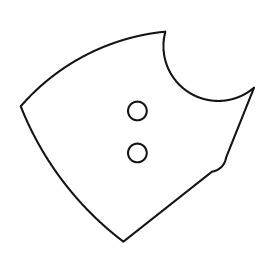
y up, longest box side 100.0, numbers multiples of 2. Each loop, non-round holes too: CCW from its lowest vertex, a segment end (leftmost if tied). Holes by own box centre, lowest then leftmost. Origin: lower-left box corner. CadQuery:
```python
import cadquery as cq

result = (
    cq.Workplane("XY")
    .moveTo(44.0, 0.0)
    .lineTo(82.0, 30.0)
    .threePointArc((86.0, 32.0), (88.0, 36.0))
    .lineTo(100.0, 66.0)
    .threePointArc((72.0, 64.0), (62.0, 90.0))
    .threePointArc((28.0, 80.0), (0.0, 58.0))
    .threePointArc((18.0, 26.0), (44.0, 0.0))
    .close()
    .moveTo(50.0, 38.0)
    .circle(4.0)
    .moveTo(50.0, 56.0)
    .circle(4.0)
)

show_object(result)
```